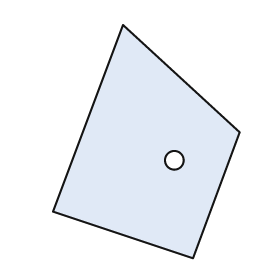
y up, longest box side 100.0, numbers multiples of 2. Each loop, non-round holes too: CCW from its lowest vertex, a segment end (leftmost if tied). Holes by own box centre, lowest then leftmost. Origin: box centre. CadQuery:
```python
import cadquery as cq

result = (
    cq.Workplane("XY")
    .moveTo(20.0, -50.0)
    .lineTo(40.0, 4.0)
    .lineTo(-10.0, 50.0)
    .lineTo(-40.0, -30.0)
    .close()
    .moveTo(12.0, -8.0)
    .circle(4.0)
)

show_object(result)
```